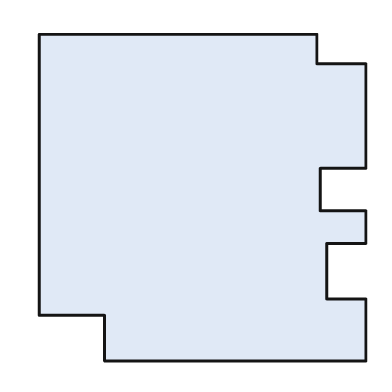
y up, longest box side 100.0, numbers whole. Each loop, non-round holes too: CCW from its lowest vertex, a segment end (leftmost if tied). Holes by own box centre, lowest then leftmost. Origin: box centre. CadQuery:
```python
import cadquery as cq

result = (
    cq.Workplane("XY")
    .moveTo(-30.0, -50.0)
    .lineTo(50.0, -50.0)
    .lineTo(50.0, -31.0)
    .lineTo(38.0, -31.0)
    .lineTo(38.0, -14.0)
    .lineTo(50.0, -14.0)
    .lineTo(50.0, -4.0)
    .lineTo(36.0, -4.0)
    .lineTo(36.0, 9.0)
    .lineTo(50.0, 9.0)
    .lineTo(50.0, 41.0)
    .lineTo(35.0, 41.0)
    .lineTo(35.0, 50.0)
    .lineTo(-50.0, 50.0)
    .lineTo(-50.0, -36.0)
    .lineTo(-30.0, -36.0)
    .close()
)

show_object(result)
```